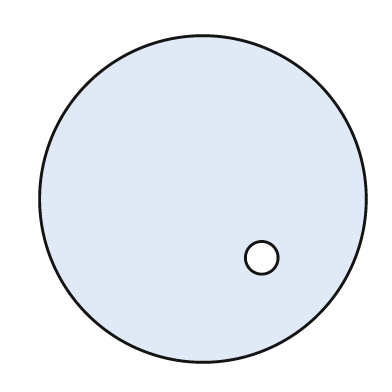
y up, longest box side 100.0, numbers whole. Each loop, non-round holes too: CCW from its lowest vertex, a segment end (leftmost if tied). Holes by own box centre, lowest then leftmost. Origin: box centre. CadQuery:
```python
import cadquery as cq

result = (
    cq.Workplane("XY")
    .moveTo(0.0, 0.0)
    .circle(50.0)
    .moveTo(18.0, -18.0)
    .circle(5.0)
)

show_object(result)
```